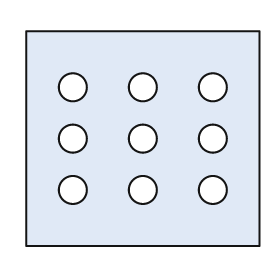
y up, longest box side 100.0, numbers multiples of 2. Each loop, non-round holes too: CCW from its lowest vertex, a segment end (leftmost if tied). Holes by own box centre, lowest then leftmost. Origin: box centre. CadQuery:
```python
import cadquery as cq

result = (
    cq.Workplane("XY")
    .moveTo(-50.0, -46.0)
    .lineTo(50.0, -46.0)
    .lineTo(50.0, 46.0)
    .lineTo(-50.0, 46.0)
    .close()
    .moveTo(-30.0, -22.0)
    .circle(6.0)
    .moveTo(0.0, -22.0)
    .circle(6.0)
    .moveTo(30.0, -22.0)
    .circle(6.0)
    .moveTo(-30.0, 0.0)
    .circle(6.0)
    .moveTo(0.0, 0.0)
    .circle(6.0)
    .moveTo(30.0, 0.0)
    .circle(6.0)
    .moveTo(-30.0, 22.0)
    .circle(6.0)
    .moveTo(0.0, 22.0)
    .circle(6.0)
    .moveTo(30.0, 22.0)
    .circle(6.0)
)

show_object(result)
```